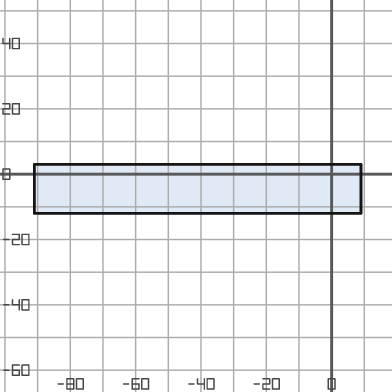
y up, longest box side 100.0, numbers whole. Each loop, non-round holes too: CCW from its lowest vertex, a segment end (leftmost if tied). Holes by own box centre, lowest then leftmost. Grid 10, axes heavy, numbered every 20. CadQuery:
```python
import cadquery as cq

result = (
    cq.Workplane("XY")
    .moveTo(-91.0, -12.0)
    .lineTo(9.0, -12.0)
    .lineTo(9.0, 3.0)
    .lineTo(-91.0, 3.0)
    .close()
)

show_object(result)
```